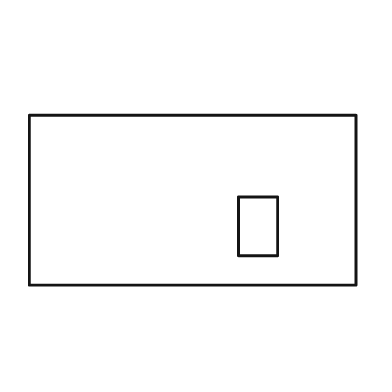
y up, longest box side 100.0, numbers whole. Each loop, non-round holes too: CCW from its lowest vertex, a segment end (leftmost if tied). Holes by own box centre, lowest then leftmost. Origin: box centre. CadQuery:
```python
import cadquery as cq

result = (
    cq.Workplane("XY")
    .moveTo(-50.0, -26.0)
    .lineTo(50.0, -26.0)
    .lineTo(50.0, 26.0)
    .lineTo(-50.0, 26.0)
    .close()
    .moveTo(14.0, -17.0)
    .lineTo(26.0, -17.0)
    .lineTo(26.0, 1.0)
    .lineTo(14.0, 1.0)
    .close()
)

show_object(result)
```